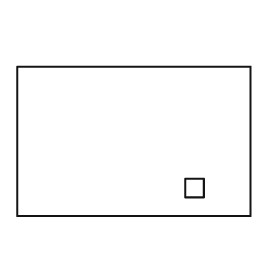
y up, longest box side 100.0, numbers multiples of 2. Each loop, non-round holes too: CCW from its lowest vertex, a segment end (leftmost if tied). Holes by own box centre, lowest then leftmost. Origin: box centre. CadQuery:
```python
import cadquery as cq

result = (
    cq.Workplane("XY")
    .moveTo(-50.0, -32.0)
    .lineTo(50.0, -32.0)
    .lineTo(50.0, 32.0)
    .lineTo(-50.0, 32.0)
    .close()
    .moveTo(22.0, -24.0)
    .lineTo(30.0, -24.0)
    .lineTo(30.0, -16.0)
    .lineTo(22.0, -16.0)
    .close()
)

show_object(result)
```